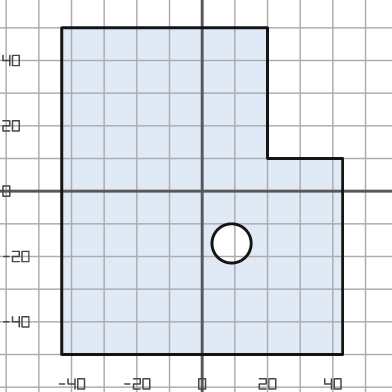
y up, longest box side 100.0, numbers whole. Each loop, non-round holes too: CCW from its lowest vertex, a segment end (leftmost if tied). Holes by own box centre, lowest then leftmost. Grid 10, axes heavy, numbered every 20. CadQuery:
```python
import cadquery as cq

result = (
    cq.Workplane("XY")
    .moveTo(-43.0, -50.0)
    .lineTo(43.0, -50.0)
    .lineTo(43.0, 10.0)
    .lineTo(20.0, 10.0)
    .lineTo(20.0, 50.0)
    .lineTo(-43.0, 50.0)
    .close()
    .moveTo(9.0, -16.0)
    .circle(6.0)
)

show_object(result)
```